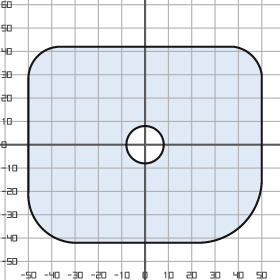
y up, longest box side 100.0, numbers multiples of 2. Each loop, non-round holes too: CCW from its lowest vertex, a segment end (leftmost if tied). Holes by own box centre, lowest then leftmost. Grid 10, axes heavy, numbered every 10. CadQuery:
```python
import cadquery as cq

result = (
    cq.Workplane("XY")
    .moveTo(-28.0, -42.0)
    .lineTo(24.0, -42.0)
    .threePointArc((42.0, -34.0), (50.0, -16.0))
    .lineTo(50.0, 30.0)
    .threePointArc((46.0, 38.0), (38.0, 42.0))
    .lineTo(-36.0, 42.0)
    .threePointArc((-46.0, 38.0), (-50.0, 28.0))
    .lineTo(-50.0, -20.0)
    .threePointArc((-44.0, -36.0), (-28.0, -42.0))
    .close()
    .moveTo(0.0, 0.0)
    .circle(8.0)
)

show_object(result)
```